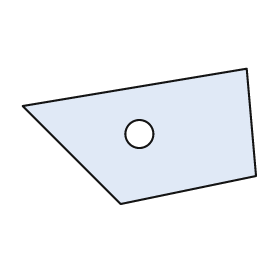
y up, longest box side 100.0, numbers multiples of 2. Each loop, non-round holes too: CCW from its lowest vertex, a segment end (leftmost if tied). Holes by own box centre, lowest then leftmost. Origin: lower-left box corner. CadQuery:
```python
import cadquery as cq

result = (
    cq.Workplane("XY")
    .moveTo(42.0, 0.0)
    .lineTo(100.0, 12.0)
    .lineTo(96.0, 58.0)
    .lineTo(0.0, 42.0)
    .close()
    .moveTo(50.0, 30.0)
    .circle(6.0)
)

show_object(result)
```